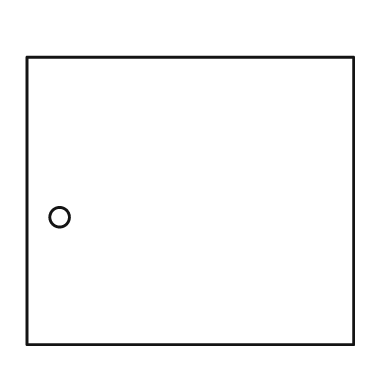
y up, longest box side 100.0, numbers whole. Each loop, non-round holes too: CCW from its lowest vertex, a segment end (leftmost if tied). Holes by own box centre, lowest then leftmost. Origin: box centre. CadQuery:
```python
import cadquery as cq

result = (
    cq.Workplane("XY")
    .moveTo(-50.0, -44.0)
    .lineTo(50.0, -44.0)
    .lineTo(50.0, 44.0)
    .lineTo(-50.0, 44.0)
    .close()
    .moveTo(-40.0, -5.0)
    .circle(3.0)
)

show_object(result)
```